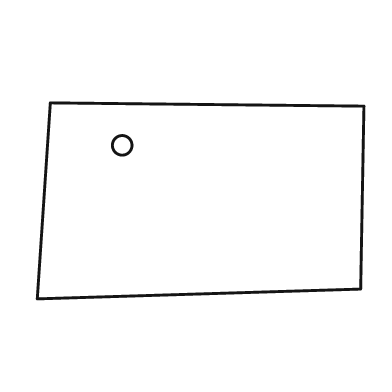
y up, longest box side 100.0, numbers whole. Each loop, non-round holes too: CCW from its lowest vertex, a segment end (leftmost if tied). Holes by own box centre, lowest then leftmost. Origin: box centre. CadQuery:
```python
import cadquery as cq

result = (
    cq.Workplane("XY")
    .moveTo(-50.0, -30.0)
    .lineTo(49.0, -27.0)
    .lineTo(50.0, 29.0)
    .lineTo(-46.0, 30.0)
    .close()
    .moveTo(-24.0, 17.0)
    .circle(3.0)
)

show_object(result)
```